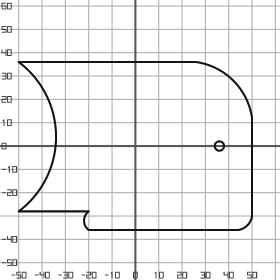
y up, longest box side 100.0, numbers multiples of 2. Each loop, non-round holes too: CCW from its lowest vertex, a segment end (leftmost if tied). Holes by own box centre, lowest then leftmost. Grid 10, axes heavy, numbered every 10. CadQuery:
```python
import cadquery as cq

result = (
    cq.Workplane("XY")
    .moveTo(-20.0, -36.0)
    .lineTo(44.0, -36.0)
    .threePointArc((48.0, -34.0), (50.0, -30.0))
    .lineTo(50.0, 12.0)
    .threePointArc((42.0, 28.0), (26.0, 36.0))
    .lineTo(-50.0, 36.0)
    .threePointArc((-34.0, 4.0), (-50.0, -28.0))
    .lineTo(-20.0, -28.0)
    .threePointArc((-22.0, -32.0), (-20.0, -36.0))
    .close()
    .moveTo(36.0, 0.0)
    .circle(2.0)
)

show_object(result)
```